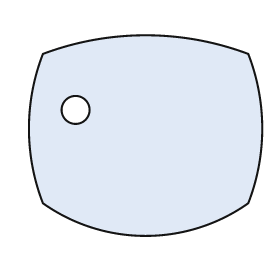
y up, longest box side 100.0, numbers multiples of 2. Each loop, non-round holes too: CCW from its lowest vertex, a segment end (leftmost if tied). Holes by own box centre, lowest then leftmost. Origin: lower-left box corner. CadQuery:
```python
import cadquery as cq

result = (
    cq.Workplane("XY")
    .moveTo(6.0, 14.0)
    .threePointArc((50.0, 0.0), (94.0, 14.0))
    .threePointArc((100.0, 46.0), (94.0, 78.0))
    .threePointArc((50.0, 86.0), (6.0, 78.0))
    .threePointArc((0.0, 46.0), (6.0, 14.0))
    .close()
    .moveTo(20.0, 54.0)
    .circle(6.0)
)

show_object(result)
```